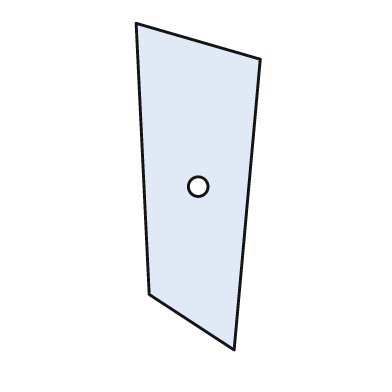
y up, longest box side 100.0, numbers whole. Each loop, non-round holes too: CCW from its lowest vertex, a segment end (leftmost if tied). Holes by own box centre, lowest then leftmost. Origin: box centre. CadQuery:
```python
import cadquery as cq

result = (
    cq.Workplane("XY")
    .moveTo(11.0, -50.0)
    .lineTo(19.0, 39.0)
    .lineTo(-19.0, 50.0)
    .lineTo(-15.0, -33.0)
    .close()
    .moveTo(0.0, 0.0)
    .circle(3.0)
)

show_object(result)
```